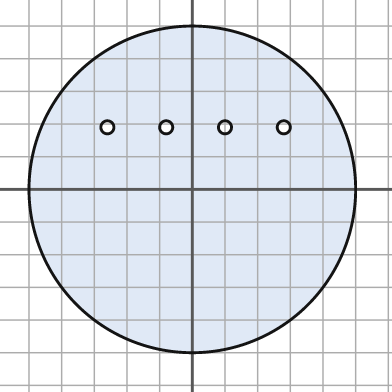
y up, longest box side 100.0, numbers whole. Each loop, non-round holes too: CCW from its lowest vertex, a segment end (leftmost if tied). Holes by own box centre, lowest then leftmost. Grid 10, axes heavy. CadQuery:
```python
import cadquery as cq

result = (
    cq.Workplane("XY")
    .moveTo(0.0, 0.0)
    .circle(50.0)
    .moveTo(-26.0, 19.0)
    .circle(2.0)
    .moveTo(-8.0, 19.0)
    .circle(2.0)
    .moveTo(10.0, 19.0)
    .circle(2.0)
    .moveTo(28.0, 19.0)
    .circle(2.0)
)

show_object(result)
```